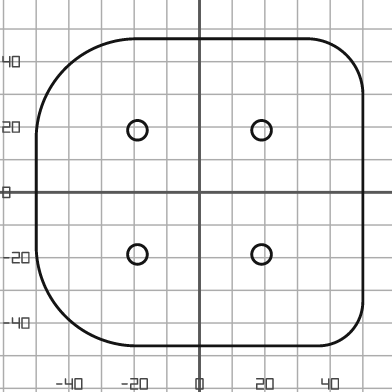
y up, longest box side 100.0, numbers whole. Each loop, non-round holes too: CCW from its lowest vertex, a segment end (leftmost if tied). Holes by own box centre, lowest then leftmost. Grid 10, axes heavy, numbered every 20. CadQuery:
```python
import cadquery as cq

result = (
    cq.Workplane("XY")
    .moveTo(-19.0, -47.0)
    .lineTo(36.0, -47.0)
    .threePointArc((46.0, -43.0), (50.0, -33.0))
    .lineTo(50.0, 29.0)
    .threePointArc((45.0, 42.0), (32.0, 47.0))
    .lineTo(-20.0, 47.0)
    .threePointArc((-41.0, 38.0), (-50.0, 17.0))
    .lineTo(-50.0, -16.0)
    .threePointArc((-41.0, -38.0), (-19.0, -47.0))
    .close()
    .moveTo(-19.0, -19.0)
    .circle(3.0)
    .moveTo(19.0, -19.0)
    .circle(3.0)
    .moveTo(-19.0, 19.0)
    .circle(3.0)
    .moveTo(19.0, 19.0)
    .circle(3.0)
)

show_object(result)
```